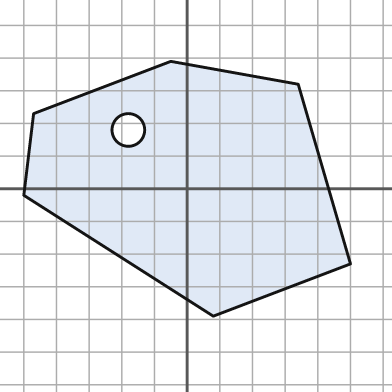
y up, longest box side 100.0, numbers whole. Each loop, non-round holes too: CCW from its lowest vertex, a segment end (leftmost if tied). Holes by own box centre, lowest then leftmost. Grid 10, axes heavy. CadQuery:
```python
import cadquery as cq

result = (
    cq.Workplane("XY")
    .moveTo(8.0, -39.0)
    .lineTo(50.0, -23.0)
    .lineTo(34.0, 32.0)
    .lineTo(-5.0, 39.0)
    .lineTo(-47.0, 23.0)
    .lineTo(-50.0, -2.0)
    .close()
    .moveTo(-18.0, 18.0)
    .circle(5.0)
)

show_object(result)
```